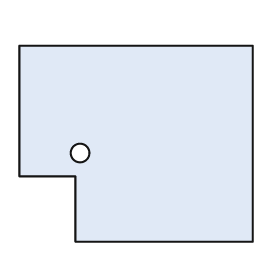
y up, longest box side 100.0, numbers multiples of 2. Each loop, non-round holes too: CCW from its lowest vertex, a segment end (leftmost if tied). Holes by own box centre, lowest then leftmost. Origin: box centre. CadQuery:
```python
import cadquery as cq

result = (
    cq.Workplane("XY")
    .moveTo(-26.0, -42.0)
    .lineTo(50.0, -42.0)
    .lineTo(50.0, 42.0)
    .lineTo(-50.0, 42.0)
    .lineTo(-50.0, -14.0)
    .lineTo(-26.0, -14.0)
    .close()
    .moveTo(-24.0, -4.0)
    .circle(4.0)
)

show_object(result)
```